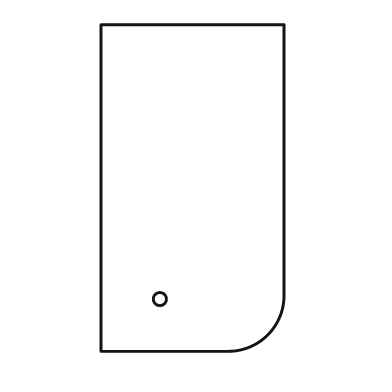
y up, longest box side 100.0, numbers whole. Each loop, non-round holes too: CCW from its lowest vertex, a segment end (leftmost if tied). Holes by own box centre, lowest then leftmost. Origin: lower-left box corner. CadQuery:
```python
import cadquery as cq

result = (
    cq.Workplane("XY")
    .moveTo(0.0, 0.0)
    .lineTo(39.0, 0.0)
    .threePointArc((51.0, 5.0), (56.0, 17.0))
    .lineTo(56.0, 100.0)
    .lineTo(0.0, 100.0)
    .close()
    .moveTo(18.0, 16.0)
    .circle(2.0)
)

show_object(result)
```